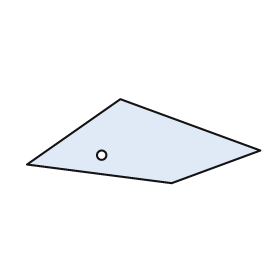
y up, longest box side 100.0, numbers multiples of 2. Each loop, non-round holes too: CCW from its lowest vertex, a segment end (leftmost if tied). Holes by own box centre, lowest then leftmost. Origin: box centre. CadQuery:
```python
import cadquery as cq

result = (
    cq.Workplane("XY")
    .moveTo(12.0, -18.0)
    .lineTo(50.0, -4.0)
    .lineTo(-10.0, 18.0)
    .lineTo(-50.0, -10.0)
    .close()
    .moveTo(-18.0, -6.0)
    .circle(2.0)
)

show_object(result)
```